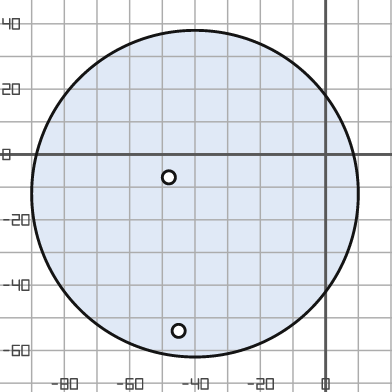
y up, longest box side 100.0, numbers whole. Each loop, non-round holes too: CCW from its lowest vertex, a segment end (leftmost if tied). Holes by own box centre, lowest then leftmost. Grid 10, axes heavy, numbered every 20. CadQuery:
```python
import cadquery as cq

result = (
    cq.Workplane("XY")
    .moveTo(-40.0, -12.0)
    .circle(50.0)
    .moveTo(-45.0, -54.0)
    .circle(2.0)
    .moveTo(-48.0, -7.0)
    .circle(2.0)
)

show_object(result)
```